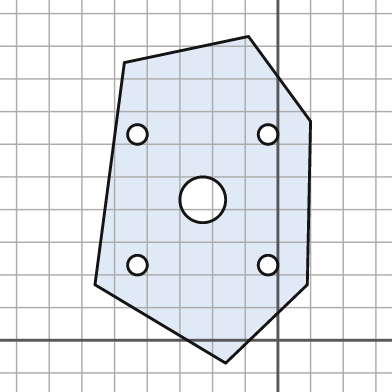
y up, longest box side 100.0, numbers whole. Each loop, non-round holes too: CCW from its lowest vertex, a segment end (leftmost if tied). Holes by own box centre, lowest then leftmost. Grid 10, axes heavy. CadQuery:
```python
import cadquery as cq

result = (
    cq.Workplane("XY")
    .moveTo(-16.0, -7.0)
    .lineTo(9.0, 17.0)
    .lineTo(10.0, 67.0)
    .lineTo(-9.0, 93.0)
    .lineTo(-47.0, 85.0)
    .lineTo(-56.0, 17.0)
    .close()
    .moveTo(-43.0, 23.0)
    .circle(3.0)
    .moveTo(-3.0, 23.0)
    .circle(3.0)
    .moveTo(-23.0, 43.0)
    .circle(7.0)
    .moveTo(-43.0, 63.0)
    .circle(3.0)
    .moveTo(-3.0, 63.0)
    .circle(3.0)
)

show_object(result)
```